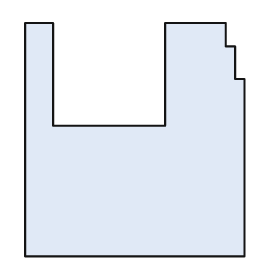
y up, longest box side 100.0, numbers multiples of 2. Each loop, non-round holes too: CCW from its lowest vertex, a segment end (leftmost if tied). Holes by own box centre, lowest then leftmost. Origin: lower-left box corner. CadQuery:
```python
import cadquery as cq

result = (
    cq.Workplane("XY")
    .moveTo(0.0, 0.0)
    .lineTo(94.0, 0.0)
    .lineTo(94.0, 76.0)
    .lineTo(90.0, 76.0)
    .lineTo(90.0, 90.0)
    .lineTo(86.0, 90.0)
    .lineTo(86.0, 100.0)
    .lineTo(60.0, 100.0)
    .lineTo(60.0, 56.0)
    .lineTo(12.0, 56.0)
    .lineTo(12.0, 100.0)
    .lineTo(0.0, 100.0)
    .close()
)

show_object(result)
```